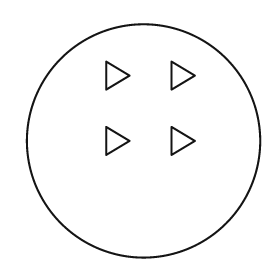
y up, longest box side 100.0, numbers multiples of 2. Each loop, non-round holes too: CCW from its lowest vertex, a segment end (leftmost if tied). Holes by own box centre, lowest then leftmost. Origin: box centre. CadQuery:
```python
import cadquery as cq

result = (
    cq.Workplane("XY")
    .moveTo(0.0, 0.0)
    .circle(50.0)
    .moveTo(-16.0, -6.0)
    .lineTo(-6.0, 0.0)
    .lineTo(-16.0, 6.0)
    .close()
    .moveTo(12.0, -6.0)
    .lineTo(22.0, 0.0)
    .lineTo(12.0, 6.0)
    .close()
    .moveTo(-16.0, 22.0)
    .lineTo(-6.0, 28.0)
    .lineTo(-16.0, 34.0)
    .close()
    .moveTo(12.0, 22.0)
    .lineTo(22.0, 28.0)
    .lineTo(12.0, 34.0)
    .close()
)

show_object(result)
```